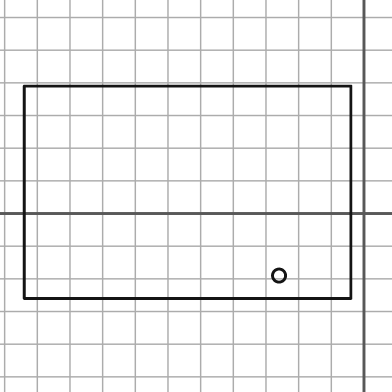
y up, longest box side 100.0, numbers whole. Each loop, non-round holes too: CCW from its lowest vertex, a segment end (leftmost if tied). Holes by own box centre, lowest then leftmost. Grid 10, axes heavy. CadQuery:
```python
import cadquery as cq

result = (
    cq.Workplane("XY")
    .moveTo(-104.0, -26.0)
    .lineTo(-4.0, -26.0)
    .lineTo(-4.0, 39.0)
    .lineTo(-104.0, 39.0)
    .close()
    .moveTo(-26.0, -19.0)
    .circle(2.0)
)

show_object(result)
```